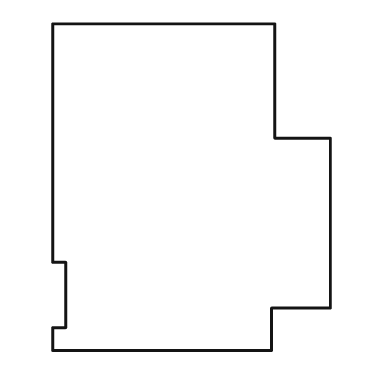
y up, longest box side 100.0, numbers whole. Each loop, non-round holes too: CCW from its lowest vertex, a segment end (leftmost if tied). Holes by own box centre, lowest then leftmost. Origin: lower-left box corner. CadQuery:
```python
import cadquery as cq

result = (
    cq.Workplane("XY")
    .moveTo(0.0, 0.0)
    .lineTo(67.0, 0.0)
    .lineTo(67.0, 13.0)
    .lineTo(85.0, 13.0)
    .lineTo(85.0, 65.0)
    .lineTo(68.0, 65.0)
    .lineTo(68.0, 100.0)
    .lineTo(0.0, 100.0)
    .lineTo(0.0, 27.0)
    .lineTo(4.0, 27.0)
    .lineTo(4.0, 7.0)
    .lineTo(0.0, 7.0)
    .close()
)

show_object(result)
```